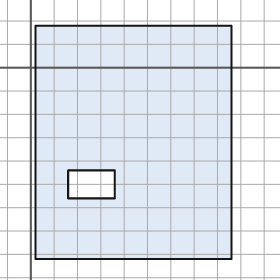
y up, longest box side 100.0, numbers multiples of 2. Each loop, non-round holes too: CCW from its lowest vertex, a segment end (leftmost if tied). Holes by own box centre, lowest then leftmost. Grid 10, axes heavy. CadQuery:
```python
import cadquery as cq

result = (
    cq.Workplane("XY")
    .moveTo(2.0, -82.0)
    .lineTo(86.0, -82.0)
    .lineTo(86.0, 18.0)
    .lineTo(2.0, 18.0)
    .close()
    .moveTo(16.0, -56.0)
    .lineTo(36.0, -56.0)
    .lineTo(36.0, -44.0)
    .lineTo(16.0, -44.0)
    .close()
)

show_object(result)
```